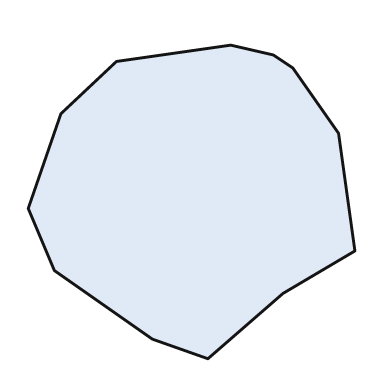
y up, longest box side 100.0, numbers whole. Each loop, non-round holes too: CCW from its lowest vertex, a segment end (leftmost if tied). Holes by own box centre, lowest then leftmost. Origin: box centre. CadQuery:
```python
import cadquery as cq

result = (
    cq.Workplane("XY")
    .moveTo(5.0, -48.0)
    .lineTo(28.0, -28.0)
    .lineTo(50.0, -15.0)
    .lineTo(45.0, 21.0)
    .lineTo(31.0, 41.0)
    .lineTo(25.0, 45.0)
    .lineTo(12.0, 48.0)
    .lineTo(-23.0, 43.0)
    .lineTo(-40.0, 27.0)
    .lineTo(-50.0, -2.0)
    .lineTo(-42.0, -21.0)
    .lineTo(-12.0, -42.0)
    .close()
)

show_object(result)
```